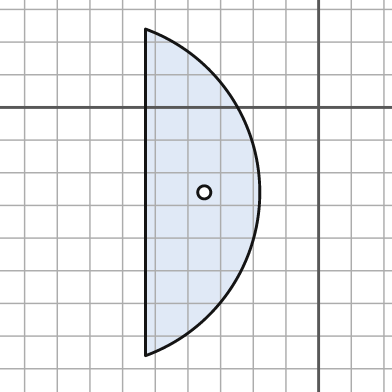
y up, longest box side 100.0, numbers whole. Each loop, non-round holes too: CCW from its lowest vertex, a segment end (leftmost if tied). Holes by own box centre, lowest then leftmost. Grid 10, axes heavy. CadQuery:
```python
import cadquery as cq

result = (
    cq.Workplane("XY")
    .moveTo(-53.0, -76.0)
    .threePointArc((-18.0, -26.0), (-53.0, 24.0))
    .close()
    .moveTo(-35.0, -26.0)
    .circle(2.0)
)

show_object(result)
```